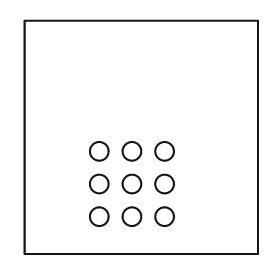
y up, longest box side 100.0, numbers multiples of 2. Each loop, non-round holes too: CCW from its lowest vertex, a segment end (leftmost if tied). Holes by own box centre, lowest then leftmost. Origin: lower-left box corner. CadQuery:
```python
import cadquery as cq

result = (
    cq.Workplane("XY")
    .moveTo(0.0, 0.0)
    .lineTo(100.0, 0.0)
    .lineTo(100.0, 100.0)
    .lineTo(0.0, 100.0)
    .close()
    .moveTo(32.0, 16.0)
    .circle(4.0)
    .moveTo(46.0, 16.0)
    .circle(4.0)
    .moveTo(60.0, 16.0)
    .circle(4.0)
    .moveTo(32.0, 30.0)
    .circle(4.0)
    .moveTo(46.0, 30.0)
    .circle(4.0)
    .moveTo(60.0, 30.0)
    .circle(4.0)
    .moveTo(32.0, 44.0)
    .circle(4.0)
    .moveTo(46.0, 44.0)
    .circle(4.0)
    .moveTo(60.0, 44.0)
    .circle(4.0)
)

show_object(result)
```